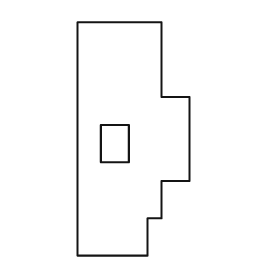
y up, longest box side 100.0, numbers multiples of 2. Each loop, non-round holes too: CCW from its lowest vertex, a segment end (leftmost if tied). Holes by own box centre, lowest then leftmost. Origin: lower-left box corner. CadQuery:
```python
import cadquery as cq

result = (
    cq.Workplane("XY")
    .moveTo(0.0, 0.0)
    .lineTo(30.0, 0.0)
    .lineTo(30.0, 16.0)
    .lineTo(36.0, 16.0)
    .lineTo(36.0, 32.0)
    .lineTo(48.0, 32.0)
    .lineTo(48.0, 68.0)
    .lineTo(36.0, 68.0)
    .lineTo(36.0, 100.0)
    .lineTo(0.0, 100.0)
    .close()
    .moveTo(10.0, 40.0)
    .lineTo(22.0, 40.0)
    .lineTo(22.0, 56.0)
    .lineTo(10.0, 56.0)
    .close()
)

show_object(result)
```